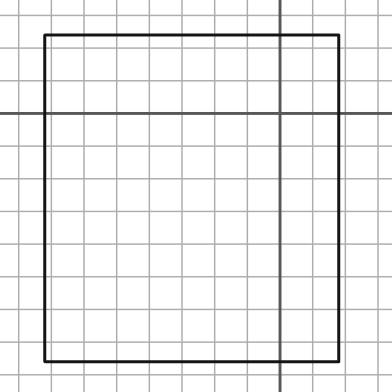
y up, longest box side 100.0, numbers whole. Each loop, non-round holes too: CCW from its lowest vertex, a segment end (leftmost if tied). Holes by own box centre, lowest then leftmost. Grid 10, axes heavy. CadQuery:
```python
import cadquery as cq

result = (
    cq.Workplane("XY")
    .moveTo(-72.0, -76.0)
    .lineTo(18.0, -76.0)
    .lineTo(18.0, 24.0)
    .lineTo(-72.0, 24.0)
    .close()
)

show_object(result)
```